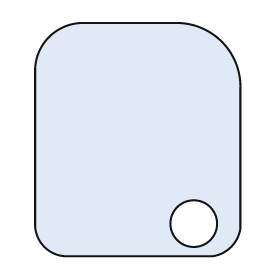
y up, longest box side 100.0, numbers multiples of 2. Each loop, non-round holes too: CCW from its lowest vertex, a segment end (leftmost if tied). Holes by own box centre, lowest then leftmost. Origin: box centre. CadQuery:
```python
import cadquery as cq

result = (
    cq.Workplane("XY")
    .moveTo(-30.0, -50.0)
    .lineTo(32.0, -50.0)
    .threePointArc((40.0, -46.0), (44.0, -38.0))
    .lineTo(44.0, 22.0)
    .threePointArc((36.0, 42.0), (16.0, 50.0))
    .lineTo(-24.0, 50.0)
    .threePointArc((-38.0, 44.0), (-44.0, 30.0))
    .lineTo(-44.0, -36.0)
    .threePointArc((-40.0, -46.0), (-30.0, -50.0))
    .close()
    .moveTo(24.0, -36.0)
    .circle(10.0)
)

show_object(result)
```